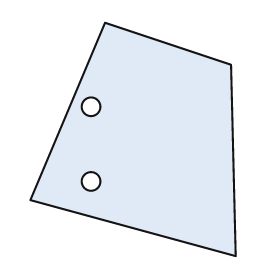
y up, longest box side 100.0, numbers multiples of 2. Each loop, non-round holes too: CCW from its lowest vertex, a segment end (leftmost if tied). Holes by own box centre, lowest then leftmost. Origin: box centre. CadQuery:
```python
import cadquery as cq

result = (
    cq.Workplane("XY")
    .moveTo(44.0, -50.0)
    .lineTo(42.0, 32.0)
    .lineTo(-12.0, 50.0)
    .lineTo(-44.0, -26.0)
    .close()
    .moveTo(-18.0, -18.0)
    .circle(4.0)
    .moveTo(-18.0, 14.0)
    .circle(4.0)
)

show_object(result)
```